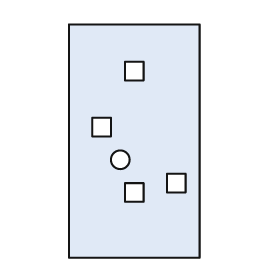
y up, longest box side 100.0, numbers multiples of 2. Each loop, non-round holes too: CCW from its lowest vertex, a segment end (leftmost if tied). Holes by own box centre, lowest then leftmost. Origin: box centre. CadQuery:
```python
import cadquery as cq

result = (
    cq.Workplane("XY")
    .moveTo(-28.0, -50.0)
    .lineTo(28.0, -50.0)
    .lineTo(28.0, 50.0)
    .lineTo(-28.0, 50.0)
    .close()
    .moveTo(-4.0, -26.0)
    .lineTo(4.0, -26.0)
    .lineTo(4.0, -18.0)
    .lineTo(-4.0, -18.0)
    .close()
    .moveTo(14.0, -22.0)
    .lineTo(22.0, -22.0)
    .lineTo(22.0, -14.0)
    .lineTo(14.0, -14.0)
    .close()
    .moveTo(-6.0, -8.0)
    .circle(4.0)
    .moveTo(-18.0, 2.0)
    .lineTo(-10.0, 2.0)
    .lineTo(-10.0, 10.0)
    .lineTo(-18.0, 10.0)
    .close()
    .moveTo(-4.0, 26.0)
    .lineTo(4.0, 26.0)
    .lineTo(4.0, 34.0)
    .lineTo(-4.0, 34.0)
    .close()
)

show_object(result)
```